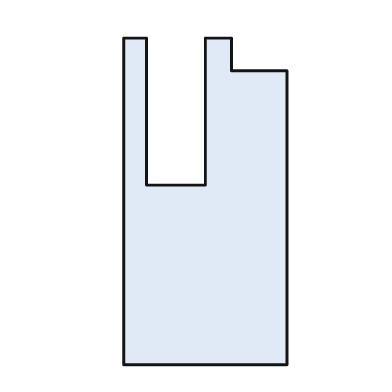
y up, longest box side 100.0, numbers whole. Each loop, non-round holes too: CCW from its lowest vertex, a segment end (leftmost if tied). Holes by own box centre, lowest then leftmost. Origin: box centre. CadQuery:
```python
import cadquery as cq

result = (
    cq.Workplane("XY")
    .moveTo(-25.0, -50.0)
    .lineTo(25.0, -50.0)
    .lineTo(25.0, 40.0)
    .lineTo(8.0, 40.0)
    .lineTo(8.0, 50.0)
    .lineTo(0.0, 50.0)
    .lineTo(0.0, 5.0)
    .lineTo(-18.0, 5.0)
    .lineTo(-18.0, 50.0)
    .lineTo(-25.0, 50.0)
    .close()
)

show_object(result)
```